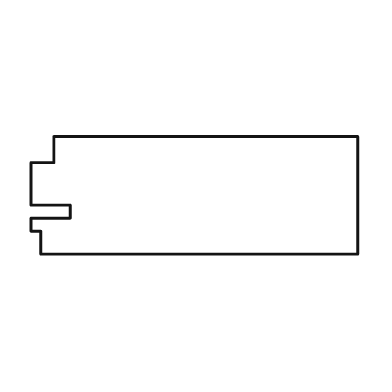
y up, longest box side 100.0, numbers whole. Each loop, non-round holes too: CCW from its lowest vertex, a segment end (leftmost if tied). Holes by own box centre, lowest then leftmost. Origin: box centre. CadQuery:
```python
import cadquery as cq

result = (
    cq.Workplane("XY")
    .moveTo(-47.0, -18.0)
    .lineTo(50.0, -18.0)
    .lineTo(50.0, 18.0)
    .lineTo(-43.0, 18.0)
    .lineTo(-43.0, 10.0)
    .lineTo(-50.0, 10.0)
    .lineTo(-50.0, -3.0)
    .lineTo(-38.0, -3.0)
    .lineTo(-38.0, -7.0)
    .lineTo(-50.0, -7.0)
    .lineTo(-50.0, -11.0)
    .lineTo(-47.0, -11.0)
    .close()
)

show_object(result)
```